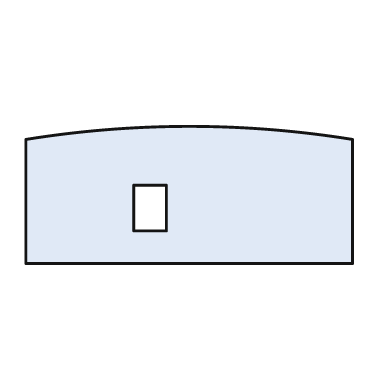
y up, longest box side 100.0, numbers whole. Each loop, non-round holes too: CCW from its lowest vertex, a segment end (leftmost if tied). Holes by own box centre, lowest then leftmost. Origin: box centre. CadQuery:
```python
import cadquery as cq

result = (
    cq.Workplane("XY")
    .moveTo(-50.0, -21.0)
    .lineTo(50.0, -21.0)
    .lineTo(50.0, 17.0)
    .threePointArc((0.0, 21.0), (-50.0, 17.0))
    .close()
    .moveTo(-17.0, -11.0)
    .lineTo(-7.0, -11.0)
    .lineTo(-7.0, 3.0)
    .lineTo(-17.0, 3.0)
    .close()
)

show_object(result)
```